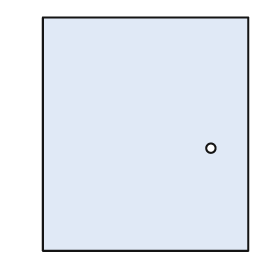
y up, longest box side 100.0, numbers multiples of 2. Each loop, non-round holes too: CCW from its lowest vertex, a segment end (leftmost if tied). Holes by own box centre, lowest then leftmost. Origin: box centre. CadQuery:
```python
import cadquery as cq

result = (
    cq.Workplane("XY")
    .moveTo(-44.0, -50.0)
    .lineTo(44.0, -50.0)
    .lineTo(44.0, 50.0)
    .lineTo(-44.0, 50.0)
    .close()
    .moveTo(28.0, -6.0)
    .circle(2.0)
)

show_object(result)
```